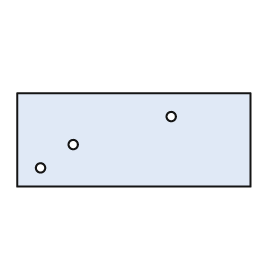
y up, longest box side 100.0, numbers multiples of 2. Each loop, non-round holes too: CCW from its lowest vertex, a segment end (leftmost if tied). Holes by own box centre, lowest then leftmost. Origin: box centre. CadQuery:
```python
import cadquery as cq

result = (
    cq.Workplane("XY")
    .moveTo(-50.0, -20.0)
    .lineTo(50.0, -20.0)
    .lineTo(50.0, 20.0)
    .lineTo(-50.0, 20.0)
    .close()
    .moveTo(-40.0, -12.0)
    .circle(2.0)
    .moveTo(-26.0, -2.0)
    .circle(2.0)
    .moveTo(16.0, 10.0)
    .circle(2.0)
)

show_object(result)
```